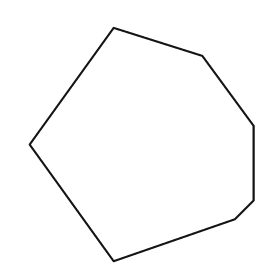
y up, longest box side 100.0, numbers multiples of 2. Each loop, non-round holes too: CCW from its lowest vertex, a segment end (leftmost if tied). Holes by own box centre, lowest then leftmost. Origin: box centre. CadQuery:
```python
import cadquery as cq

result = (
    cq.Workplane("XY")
    .moveTo(-12.0, -50.0)
    .lineTo(40.0, -32.0)
    .lineTo(48.0, -24.0)
    .lineTo(48.0, 8.0)
    .lineTo(26.0, 38.0)
    .lineTo(-12.0, 50.0)
    .lineTo(-48.0, 0.0)
    .close()
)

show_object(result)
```